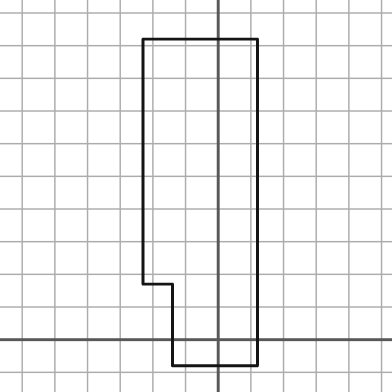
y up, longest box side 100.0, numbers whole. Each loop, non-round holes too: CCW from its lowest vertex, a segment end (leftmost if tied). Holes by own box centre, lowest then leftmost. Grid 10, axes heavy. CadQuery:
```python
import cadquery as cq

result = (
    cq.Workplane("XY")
    .moveTo(-14.0, -8.0)
    .lineTo(12.0, -8.0)
    .lineTo(12.0, 92.0)
    .lineTo(-23.0, 92.0)
    .lineTo(-23.0, 17.0)
    .lineTo(-14.0, 17.0)
    .close()
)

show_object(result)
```